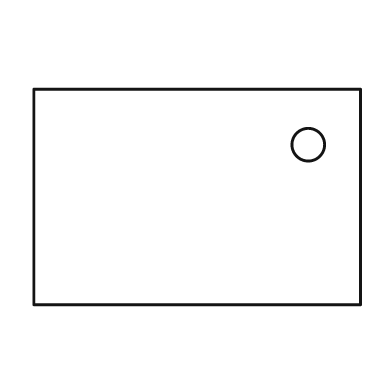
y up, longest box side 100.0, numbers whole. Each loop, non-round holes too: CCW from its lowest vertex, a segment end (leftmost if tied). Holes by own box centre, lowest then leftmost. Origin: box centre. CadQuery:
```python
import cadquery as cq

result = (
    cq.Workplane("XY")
    .moveTo(-50.0, -33.0)
    .lineTo(50.0, -33.0)
    .lineTo(50.0, 33.0)
    .lineTo(-50.0, 33.0)
    .close()
    .moveTo(34.0, 16.0)
    .circle(5.0)
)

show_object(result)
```